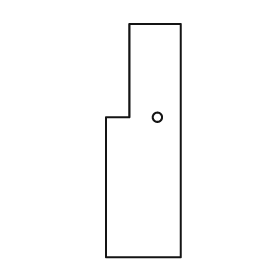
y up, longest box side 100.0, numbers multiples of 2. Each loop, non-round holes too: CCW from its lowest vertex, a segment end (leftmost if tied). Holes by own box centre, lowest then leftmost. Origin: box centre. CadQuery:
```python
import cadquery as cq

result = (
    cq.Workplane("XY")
    .moveTo(-16.0, -50.0)
    .lineTo(16.0, -50.0)
    .lineTo(16.0, 50.0)
    .lineTo(-6.0, 50.0)
    .lineTo(-6.0, 10.0)
    .lineTo(-16.0, 10.0)
    .close()
    .moveTo(6.0, 10.0)
    .circle(2.0)
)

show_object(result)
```